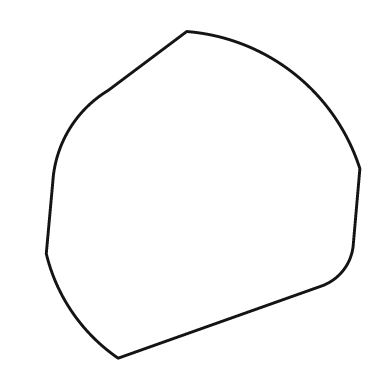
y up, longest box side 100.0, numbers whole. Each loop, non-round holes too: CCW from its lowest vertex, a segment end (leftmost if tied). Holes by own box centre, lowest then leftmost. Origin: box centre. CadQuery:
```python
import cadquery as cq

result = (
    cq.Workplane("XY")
    .moveTo(-26.0, -50.0)
    .lineTo(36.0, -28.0)
    .threePointArc((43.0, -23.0), (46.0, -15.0))
    .lineTo(48.0, 8.0)
    .threePointArc((28.0, 37.0), (-5.0, 50.0))
    .lineTo(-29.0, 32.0)
    .threePointArc((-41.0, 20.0), (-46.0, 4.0))
    .lineTo(-48.0, -18.0)
    .threePointArc((-40.0, -36.0), (-26.0, -50.0))
    .close()
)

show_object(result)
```